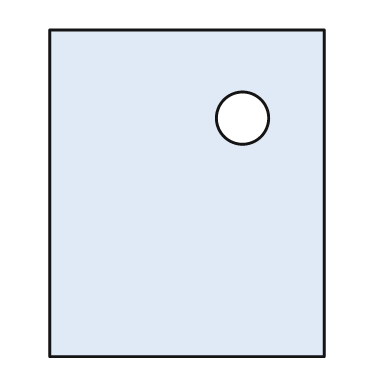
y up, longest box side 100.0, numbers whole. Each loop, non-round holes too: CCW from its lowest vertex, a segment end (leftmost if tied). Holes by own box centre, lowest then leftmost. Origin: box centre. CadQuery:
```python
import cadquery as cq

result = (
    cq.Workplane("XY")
    .moveTo(-42.0, -50.0)
    .lineTo(42.0, -50.0)
    .lineTo(42.0, 50.0)
    .lineTo(-42.0, 50.0)
    .close()
    .moveTo(17.0, 23.0)
    .circle(8.0)
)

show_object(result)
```